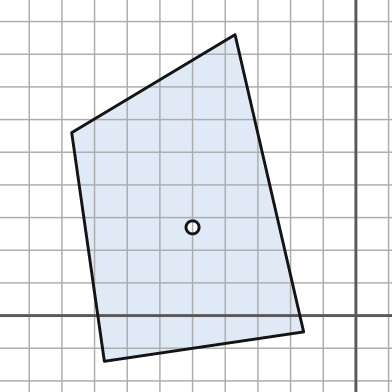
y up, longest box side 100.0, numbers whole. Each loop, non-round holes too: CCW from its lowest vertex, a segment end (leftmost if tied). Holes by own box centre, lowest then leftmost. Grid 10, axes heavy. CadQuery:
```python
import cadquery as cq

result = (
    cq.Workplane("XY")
    .moveTo(-77.0, -14.0)
    .lineTo(-16.0, -5.0)
    .lineTo(-37.0, 86.0)
    .lineTo(-87.0, 56.0)
    .close()
    .moveTo(-50.0, 27.0)
    .circle(2.0)
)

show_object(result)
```